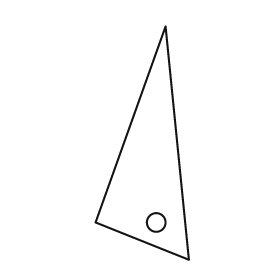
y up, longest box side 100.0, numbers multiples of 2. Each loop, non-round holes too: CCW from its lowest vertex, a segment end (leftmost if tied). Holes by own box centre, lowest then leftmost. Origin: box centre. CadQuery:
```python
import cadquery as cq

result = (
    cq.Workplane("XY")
    .moveTo(20.0, -50.0)
    .lineTo(10.0, 50.0)
    .lineTo(-20.0, -34.0)
    .close()
    .moveTo(6.0, -34.0)
    .circle(4.0)
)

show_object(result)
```